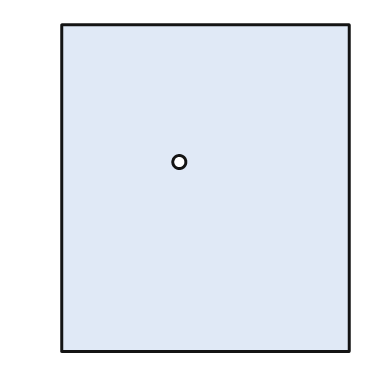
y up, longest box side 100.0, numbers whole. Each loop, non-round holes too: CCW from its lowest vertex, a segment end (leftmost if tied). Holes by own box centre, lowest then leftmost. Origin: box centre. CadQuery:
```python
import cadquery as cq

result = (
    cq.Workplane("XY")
    .moveTo(-44.0, -50.0)
    .lineTo(44.0, -50.0)
    .lineTo(44.0, 50.0)
    .lineTo(-44.0, 50.0)
    .close()
    .moveTo(-8.0, 8.0)
    .circle(2.0)
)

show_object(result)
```